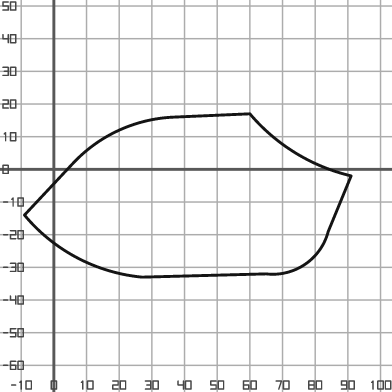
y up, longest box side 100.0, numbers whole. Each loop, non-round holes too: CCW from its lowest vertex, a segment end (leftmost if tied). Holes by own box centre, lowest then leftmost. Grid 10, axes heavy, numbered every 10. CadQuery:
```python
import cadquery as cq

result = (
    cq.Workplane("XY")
    .moveTo(27.0, -33.0)
    .lineTo(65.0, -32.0)
    .threePointArc((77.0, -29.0), (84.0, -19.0))
    .lineTo(91.0, -2.0)
    .threePointArc((74.0, 5.0), (60.0, 17.0))
    .lineTo(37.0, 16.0)
    .threePointArc((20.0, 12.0), (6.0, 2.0))
    .lineTo(-9.0, -14.0)
    .threePointArc((7.0, -27.0), (27.0, -33.0))
    .close()
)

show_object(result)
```